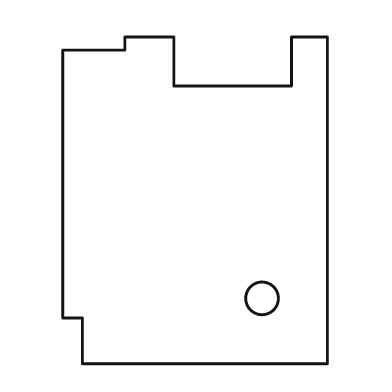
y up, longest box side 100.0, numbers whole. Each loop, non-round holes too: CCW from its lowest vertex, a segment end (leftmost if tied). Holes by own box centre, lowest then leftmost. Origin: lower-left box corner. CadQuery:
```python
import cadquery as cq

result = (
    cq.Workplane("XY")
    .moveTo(6.0, 0.0)
    .lineTo(81.0, 0.0)
    .lineTo(81.0, 100.0)
    .lineTo(70.0, 100.0)
    .lineTo(70.0, 85.0)
    .lineTo(34.0, 85.0)
    .lineTo(34.0, 100.0)
    .lineTo(19.0, 100.0)
    .lineTo(19.0, 96.0)
    .lineTo(0.0, 96.0)
    .lineTo(0.0, 14.0)
    .lineTo(6.0, 14.0)
    .close()
    .moveTo(61.0, 20.0)
    .circle(5.0)
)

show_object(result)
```